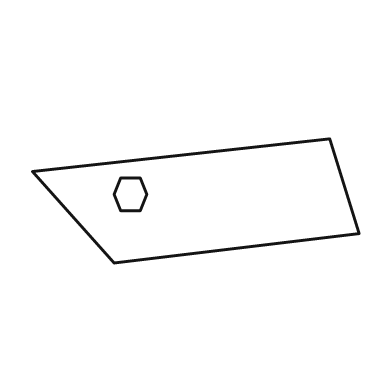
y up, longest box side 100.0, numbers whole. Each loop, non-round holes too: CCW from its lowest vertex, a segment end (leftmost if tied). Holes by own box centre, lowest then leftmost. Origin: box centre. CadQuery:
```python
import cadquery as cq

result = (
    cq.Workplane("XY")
    .moveTo(-25.0, -19.0)
    .lineTo(50.0, -10.0)
    .lineTo(41.0, 19.0)
    .lineTo(-50.0, 9.0)
    .close()
    .moveTo(-23.0, -3.0)
    .lineTo(-17.0, -3.0)
    .lineTo(-15.0, 2.0)
    .lineTo(-17.0, 7.0)
    .lineTo(-23.0, 7.0)
    .lineTo(-25.0, 2.0)
    .close()
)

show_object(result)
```